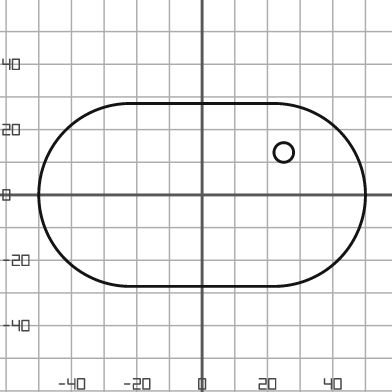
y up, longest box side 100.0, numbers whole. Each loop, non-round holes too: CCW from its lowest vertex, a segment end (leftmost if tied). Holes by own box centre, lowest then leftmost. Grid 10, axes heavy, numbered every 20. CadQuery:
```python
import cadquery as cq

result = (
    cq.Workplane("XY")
    .moveTo(-22.0, -28.0)
    .lineTo(22.0, -28.0)
    .threePointArc((50.0, 0.0), (22.0, 28.0))
    .lineTo(-22.0, 28.0)
    .threePointArc((-50.0, 0.0), (-22.0, -28.0))
    .close()
    .moveTo(25.0, 13.0)
    .circle(3.0)
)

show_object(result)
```